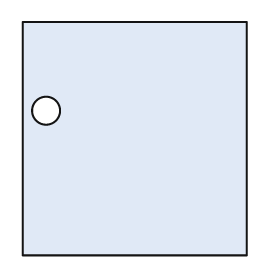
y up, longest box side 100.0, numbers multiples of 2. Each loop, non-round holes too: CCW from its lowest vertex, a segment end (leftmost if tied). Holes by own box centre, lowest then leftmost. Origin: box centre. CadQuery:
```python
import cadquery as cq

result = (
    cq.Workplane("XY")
    .moveTo(-48.0, -50.0)
    .lineTo(48.0, -50.0)
    .lineTo(48.0, 50.0)
    .lineTo(-48.0, 50.0)
    .close()
    .moveTo(-38.0, 12.0)
    .circle(6.0)
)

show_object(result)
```